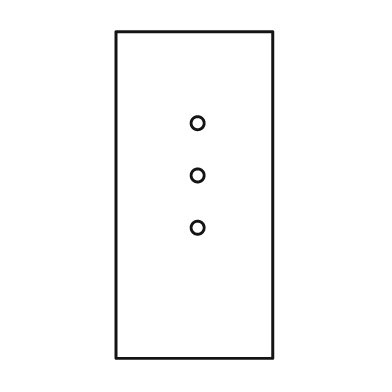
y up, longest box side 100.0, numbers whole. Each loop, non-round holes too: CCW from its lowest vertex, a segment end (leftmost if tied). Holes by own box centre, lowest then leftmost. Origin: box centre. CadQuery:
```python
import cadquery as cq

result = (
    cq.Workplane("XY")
    .moveTo(-24.0, -50.0)
    .lineTo(24.0, -50.0)
    .lineTo(24.0, 50.0)
    .lineTo(-24.0, 50.0)
    .close()
    .moveTo(1.0, -10.0)
    .circle(2.0)
    .moveTo(1.0, 6.0)
    .circle(2.0)
    .moveTo(1.0, 22.0)
    .circle(2.0)
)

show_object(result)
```